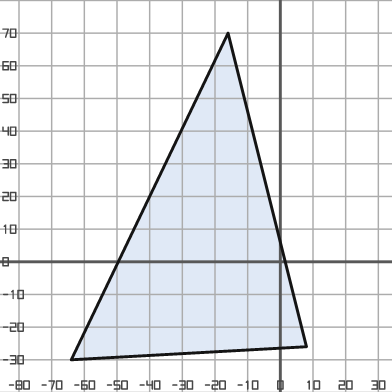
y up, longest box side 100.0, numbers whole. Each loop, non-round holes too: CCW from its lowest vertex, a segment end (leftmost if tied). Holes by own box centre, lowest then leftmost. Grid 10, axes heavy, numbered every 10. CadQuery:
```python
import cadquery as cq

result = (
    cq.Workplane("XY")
    .moveTo(-64.0, -30.0)
    .lineTo(8.0, -26.0)
    .lineTo(-16.0, 70.0)
    .close()
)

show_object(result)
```